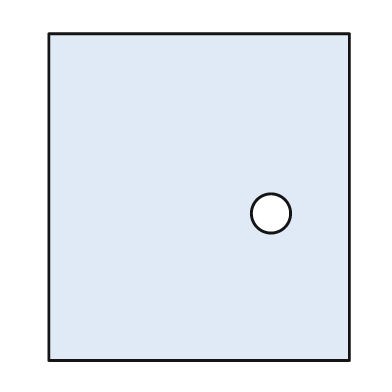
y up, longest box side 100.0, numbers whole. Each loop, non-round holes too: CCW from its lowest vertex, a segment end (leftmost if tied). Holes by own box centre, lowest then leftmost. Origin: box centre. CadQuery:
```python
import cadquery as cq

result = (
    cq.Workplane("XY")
    .moveTo(-46.0, -50.0)
    .lineTo(46.0, -50.0)
    .lineTo(46.0, 50.0)
    .lineTo(-46.0, 50.0)
    .close()
    .moveTo(22.0, -5.0)
    .circle(6.0)
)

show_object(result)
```